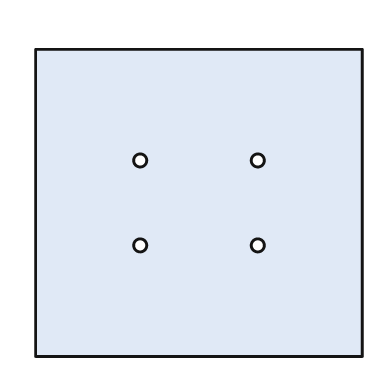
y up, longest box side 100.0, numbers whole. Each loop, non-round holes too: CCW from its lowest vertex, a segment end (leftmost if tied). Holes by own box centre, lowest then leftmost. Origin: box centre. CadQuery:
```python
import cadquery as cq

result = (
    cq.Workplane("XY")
    .moveTo(-50.0, -47.0)
    .lineTo(50.0, -47.0)
    .lineTo(50.0, 47.0)
    .lineTo(-50.0, 47.0)
    .close()
    .moveTo(-18.0, -13.0)
    .circle(2.0)
    .moveTo(18.0, -13.0)
    .circle(2.0)
    .moveTo(-18.0, 13.0)
    .circle(2.0)
    .moveTo(18.0, 13.0)
    .circle(2.0)
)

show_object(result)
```